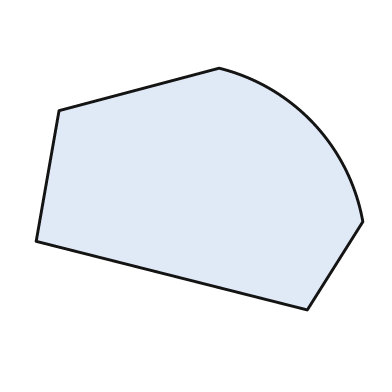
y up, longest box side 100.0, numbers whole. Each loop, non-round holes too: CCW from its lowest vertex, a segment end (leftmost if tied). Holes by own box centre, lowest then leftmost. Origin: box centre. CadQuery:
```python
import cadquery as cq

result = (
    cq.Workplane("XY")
    .moveTo(33.0, -37.0)
    .lineTo(50.0, -10.0)
    .threePointArc((35.0, 20.0), (6.0, 37.0))
    .lineTo(-43.0, 24.0)
    .lineTo(-50.0, -16.0)
    .close()
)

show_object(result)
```